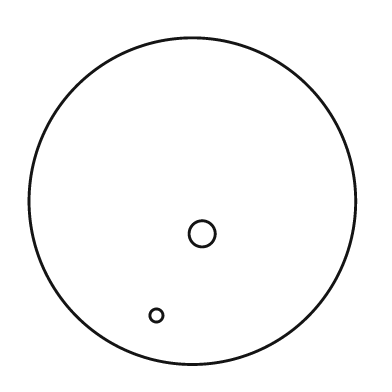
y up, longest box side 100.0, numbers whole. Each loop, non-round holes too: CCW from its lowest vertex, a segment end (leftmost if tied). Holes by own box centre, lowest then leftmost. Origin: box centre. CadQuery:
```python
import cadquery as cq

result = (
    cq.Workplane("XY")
    .moveTo(0.0, 0.0)
    .circle(50.0)
    .moveTo(-11.0, -35.0)
    .circle(2.0)
    .moveTo(3.0, -10.0)
    .circle(4.0)
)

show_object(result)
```